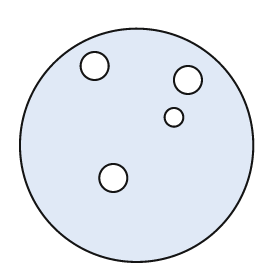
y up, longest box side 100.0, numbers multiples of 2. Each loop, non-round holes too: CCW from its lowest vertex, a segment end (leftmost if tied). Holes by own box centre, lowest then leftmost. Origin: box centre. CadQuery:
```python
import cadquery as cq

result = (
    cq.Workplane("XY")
    .moveTo(0.0, 0.0)
    .circle(50.0)
    .moveTo(-10.0, -14.0)
    .circle(6.0)
    .moveTo(16.0, 12.0)
    .circle(4.0)
    .moveTo(22.0, 28.0)
    .circle(6.0)
    .moveTo(-18.0, 34.0)
    .circle(6.0)
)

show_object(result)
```